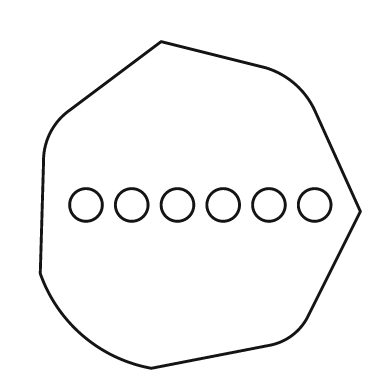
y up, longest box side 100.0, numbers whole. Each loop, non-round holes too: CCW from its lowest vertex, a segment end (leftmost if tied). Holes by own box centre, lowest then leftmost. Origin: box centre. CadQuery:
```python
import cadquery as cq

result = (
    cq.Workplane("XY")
    .moveTo(-15.0, -50.0)
    .lineTo(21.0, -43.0)
    .threePointArc((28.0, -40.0), (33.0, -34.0))
    .lineTo(49.0, -2.0)
    .lineTo(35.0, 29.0)
    .threePointArc((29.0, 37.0), (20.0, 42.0))
    .lineTo(-12.0, 50.0)
    .lineTo(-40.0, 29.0)
    .threePointArc((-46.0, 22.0), (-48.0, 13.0))
    .lineTo(-49.0, -21.0)
    .threePointArc((-36.0, -40.0), (-15.0, -50.0))
    .close()
    .moveTo(-35.0, 0.0)
    .circle(5.0)
    .moveTo(-21.0, 0.0)
    .circle(5.0)
    .moveTo(-7.0, 0.0)
    .circle(5.0)
    .moveTo(7.0, 0.0)
    .circle(5.0)
    .moveTo(21.0, 0.0)
    .circle(5.0)
    .moveTo(35.0, 0.0)
    .circle(5.0)
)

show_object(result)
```